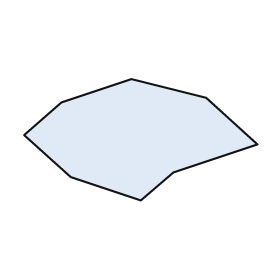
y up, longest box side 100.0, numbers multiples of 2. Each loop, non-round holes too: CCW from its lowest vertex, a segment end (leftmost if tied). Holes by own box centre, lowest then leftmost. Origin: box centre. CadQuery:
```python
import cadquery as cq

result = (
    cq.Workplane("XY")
    .moveTo(0.0, -26.0)
    .lineTo(14.0, -14.0)
    .lineTo(50.0, -2.0)
    .lineTo(28.0, 18.0)
    .lineTo(-4.0, 26.0)
    .lineTo(-34.0, 16.0)
    .lineTo(-50.0, 2.0)
    .lineTo(-30.0, -16.0)
    .close()
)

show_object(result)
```